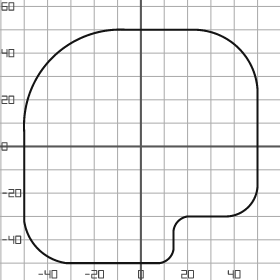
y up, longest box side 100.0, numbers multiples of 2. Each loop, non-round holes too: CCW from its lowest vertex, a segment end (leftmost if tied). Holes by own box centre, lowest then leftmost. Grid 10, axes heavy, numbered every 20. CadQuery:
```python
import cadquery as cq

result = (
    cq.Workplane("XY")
    .moveTo(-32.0, -50.0)
    .lineTo(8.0, -50.0)
    .threePointArc((12.0, -48.0), (14.0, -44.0))
    .lineTo(14.0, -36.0)
    .threePointArc((16.0, -32.0), (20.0, -30.0))
    .lineTo(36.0, -30.0)
    .threePointArc((46.0, -26.0), (50.0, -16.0))
    .lineTo(50.0, 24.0)
    .threePointArc((42.0, 42.0), (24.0, 50.0))
    .lineTo(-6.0, 50.0)
    .threePointArc((-38.0, 38.0), (-50.0, 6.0))
    .lineTo(-50.0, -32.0)
    .threePointArc((-44.0, -44.0), (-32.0, -50.0))
    .close()
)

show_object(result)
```